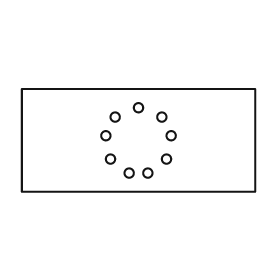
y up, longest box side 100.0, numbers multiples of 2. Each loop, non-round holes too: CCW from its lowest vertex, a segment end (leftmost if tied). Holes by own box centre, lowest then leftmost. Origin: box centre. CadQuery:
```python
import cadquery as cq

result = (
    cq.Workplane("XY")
    .moveTo(-50.0, -22.0)
    .lineTo(50.0, -22.0)
    .lineTo(50.0, 22.0)
    .lineTo(-50.0, 22.0)
    .close()
    .moveTo(-4.0, -14.0)
    .circle(2.0)
    .moveTo(4.0, -14.0)
    .circle(2.0)
    .moveTo(-12.0, -8.0)
    .circle(2.0)
    .moveTo(12.0, -8.0)
    .circle(2.0)
    .moveTo(-14.0, 2.0)
    .circle(2.0)
    .moveTo(14.0, 2.0)
    .circle(2.0)
    .moveTo(-10.0, 10.0)
    .circle(2.0)
    .moveTo(10.0, 10.0)
    .circle(2.0)
    .moveTo(0.0, 14.0)
    .circle(2.0)
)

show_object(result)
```